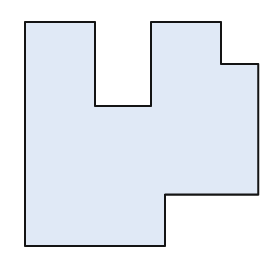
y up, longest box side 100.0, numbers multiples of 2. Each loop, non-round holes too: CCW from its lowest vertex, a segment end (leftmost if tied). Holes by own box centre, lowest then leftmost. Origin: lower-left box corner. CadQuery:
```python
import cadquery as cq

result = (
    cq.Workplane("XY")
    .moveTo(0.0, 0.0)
    .lineTo(60.0, 0.0)
    .lineTo(60.0, 22.0)
    .lineTo(100.0, 22.0)
    .lineTo(100.0, 78.0)
    .lineTo(84.0, 78.0)
    .lineTo(84.0, 96.0)
    .lineTo(54.0, 96.0)
    .lineTo(54.0, 60.0)
    .lineTo(30.0, 60.0)
    .lineTo(30.0, 96.0)
    .lineTo(0.0, 96.0)
    .close()
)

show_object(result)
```